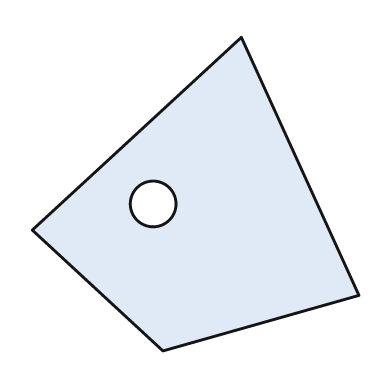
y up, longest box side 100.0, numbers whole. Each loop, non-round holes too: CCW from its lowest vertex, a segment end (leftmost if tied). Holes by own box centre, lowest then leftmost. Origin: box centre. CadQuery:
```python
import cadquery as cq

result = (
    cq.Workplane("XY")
    .moveTo(-10.0, -48.0)
    .lineTo(50.0, -31.0)
    .lineTo(14.0, 48.0)
    .lineTo(-50.0, -11.0)
    .close()
    .moveTo(-13.0, -3.0)
    .circle(7.0)
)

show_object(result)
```